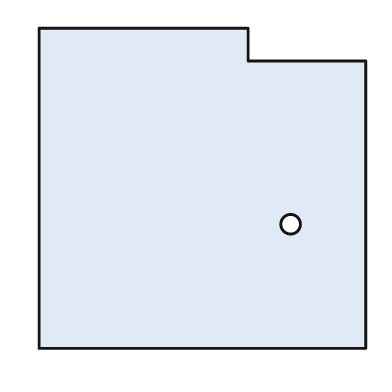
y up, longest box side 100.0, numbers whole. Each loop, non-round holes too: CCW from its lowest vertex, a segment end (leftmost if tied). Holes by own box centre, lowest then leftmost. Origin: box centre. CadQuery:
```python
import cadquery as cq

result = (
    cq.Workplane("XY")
    .moveTo(-50.0, -49.0)
    .lineTo(50.0, -49.0)
    .lineTo(50.0, 39.0)
    .lineTo(14.0, 39.0)
    .lineTo(14.0, 49.0)
    .lineTo(-50.0, 49.0)
    .close()
    .moveTo(27.0, -11.0)
    .circle(3.0)
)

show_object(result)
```